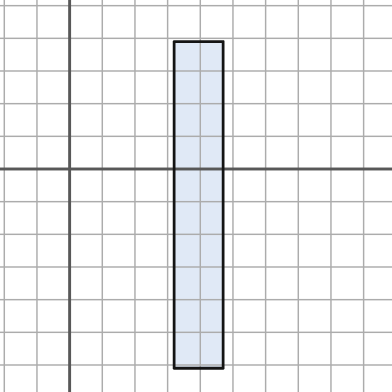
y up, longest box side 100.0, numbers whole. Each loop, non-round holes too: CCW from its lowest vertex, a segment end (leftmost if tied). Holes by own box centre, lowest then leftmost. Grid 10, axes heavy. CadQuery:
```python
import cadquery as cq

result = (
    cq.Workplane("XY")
    .moveTo(32.0, -61.0)
    .lineTo(47.0, -61.0)
    .lineTo(47.0, 39.0)
    .lineTo(32.0, 39.0)
    .close()
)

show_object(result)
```